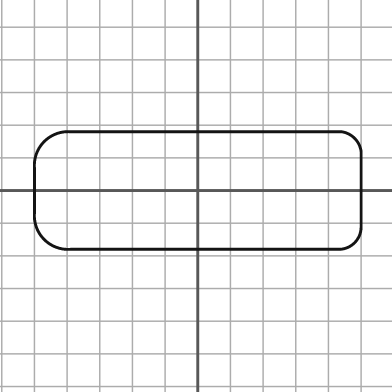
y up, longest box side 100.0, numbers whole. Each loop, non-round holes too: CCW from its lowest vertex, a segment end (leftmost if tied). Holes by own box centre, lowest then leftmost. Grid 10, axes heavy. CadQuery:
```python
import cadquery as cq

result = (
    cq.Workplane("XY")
    .moveTo(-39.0, -18.0)
    .lineTo(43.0, -18.0)
    .threePointArc((48.0, -16.0), (50.0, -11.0))
    .lineTo(50.0, 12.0)
    .threePointArc((48.0, 16.0), (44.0, 18.0))
    .lineTo(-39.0, 18.0)
    .threePointArc((-47.0, 15.0), (-50.0, 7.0))
    .lineTo(-50.0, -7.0)
    .threePointArc((-47.0, -15.0), (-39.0, -18.0))
    .close()
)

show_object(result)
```